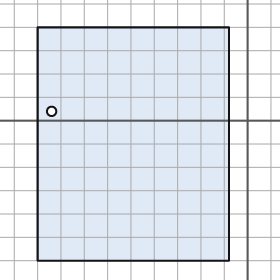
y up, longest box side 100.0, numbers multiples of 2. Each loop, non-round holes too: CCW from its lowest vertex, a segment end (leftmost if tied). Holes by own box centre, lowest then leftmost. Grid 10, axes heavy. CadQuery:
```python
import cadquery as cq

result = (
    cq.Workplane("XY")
    .moveTo(-90.0, -60.0)
    .lineTo(-8.0, -60.0)
    .lineTo(-8.0, 40.0)
    .lineTo(-90.0, 40.0)
    .close()
    .moveTo(-84.0, 4.0)
    .circle(2.0)
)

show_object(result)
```